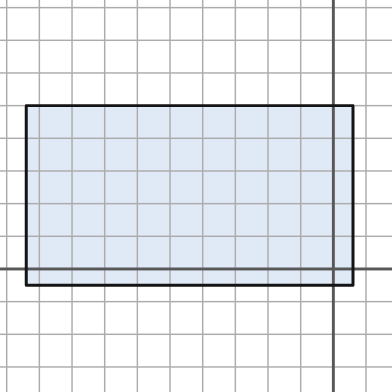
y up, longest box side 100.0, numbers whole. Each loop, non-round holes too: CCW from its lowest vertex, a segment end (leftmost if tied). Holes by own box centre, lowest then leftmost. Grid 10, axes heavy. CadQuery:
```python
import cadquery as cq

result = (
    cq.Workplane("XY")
    .moveTo(-94.0, -5.0)
    .lineTo(6.0, -5.0)
    .lineTo(6.0, 50.0)
    .lineTo(-94.0, 50.0)
    .close()
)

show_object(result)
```